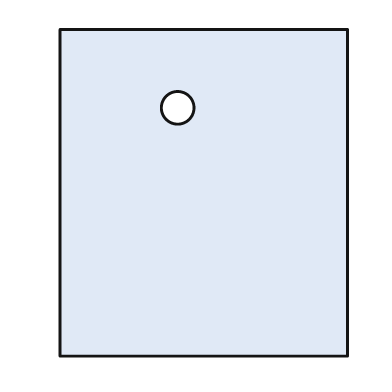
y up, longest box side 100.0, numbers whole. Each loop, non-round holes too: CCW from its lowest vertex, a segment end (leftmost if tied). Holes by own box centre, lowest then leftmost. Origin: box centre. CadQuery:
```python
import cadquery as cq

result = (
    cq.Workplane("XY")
    .moveTo(-44.0, -50.0)
    .lineTo(44.0, -50.0)
    .lineTo(44.0, 50.0)
    .lineTo(-44.0, 50.0)
    .close()
    .moveTo(-8.0, 26.0)
    .circle(5.0)
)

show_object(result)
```